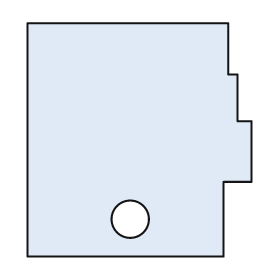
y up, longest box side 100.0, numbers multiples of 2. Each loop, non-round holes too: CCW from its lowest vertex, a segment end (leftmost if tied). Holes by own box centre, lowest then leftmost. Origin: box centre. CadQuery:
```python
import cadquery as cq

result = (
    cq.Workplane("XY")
    .moveTo(-48.0, -50.0)
    .lineTo(36.0, -50.0)
    .lineTo(36.0, -18.0)
    .lineTo(48.0, -18.0)
    .lineTo(48.0, 8.0)
    .lineTo(42.0, 8.0)
    .lineTo(42.0, 28.0)
    .lineTo(38.0, 28.0)
    .lineTo(38.0, 50.0)
    .lineTo(-48.0, 50.0)
    .close()
    .moveTo(-4.0, -34.0)
    .circle(8.0)
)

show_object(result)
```